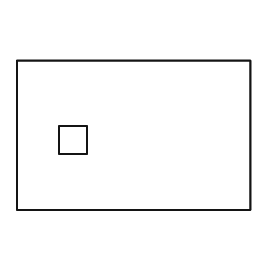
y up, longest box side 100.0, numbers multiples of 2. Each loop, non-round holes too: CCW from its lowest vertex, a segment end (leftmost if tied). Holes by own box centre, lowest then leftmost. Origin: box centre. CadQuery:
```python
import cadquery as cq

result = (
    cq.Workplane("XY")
    .moveTo(-50.0, -32.0)
    .lineTo(50.0, -32.0)
    .lineTo(50.0, 32.0)
    .lineTo(-50.0, 32.0)
    .close()
    .moveTo(-32.0, -8.0)
    .lineTo(-20.0, -8.0)
    .lineTo(-20.0, 4.0)
    .lineTo(-32.0, 4.0)
    .close()
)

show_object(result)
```